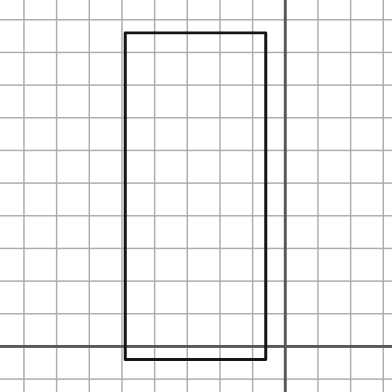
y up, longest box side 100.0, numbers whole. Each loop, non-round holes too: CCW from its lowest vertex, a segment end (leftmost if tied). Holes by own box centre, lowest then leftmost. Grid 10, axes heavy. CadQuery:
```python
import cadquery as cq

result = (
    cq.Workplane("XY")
    .moveTo(-49.0, -4.0)
    .lineTo(-6.0, -4.0)
    .lineTo(-6.0, 96.0)
    .lineTo(-49.0, 96.0)
    .close()
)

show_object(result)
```